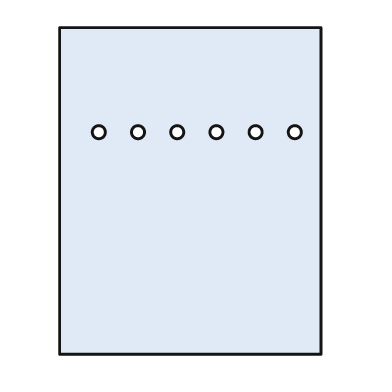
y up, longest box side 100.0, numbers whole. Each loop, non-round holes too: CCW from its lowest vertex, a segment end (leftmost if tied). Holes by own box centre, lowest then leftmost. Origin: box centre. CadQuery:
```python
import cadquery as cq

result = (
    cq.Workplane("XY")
    .moveTo(-40.0, -50.0)
    .lineTo(40.0, -50.0)
    .lineTo(40.0, 50.0)
    .lineTo(-40.0, 50.0)
    .close()
    .moveTo(-28.0, 18.0)
    .circle(2.0)
    .moveTo(-16.0, 18.0)
    .circle(2.0)
    .moveTo(-4.0, 18.0)
    .circle(2.0)
    .moveTo(8.0, 18.0)
    .circle(2.0)
    .moveTo(20.0, 18.0)
    .circle(2.0)
    .moveTo(32.0, 18.0)
    .circle(2.0)
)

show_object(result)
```